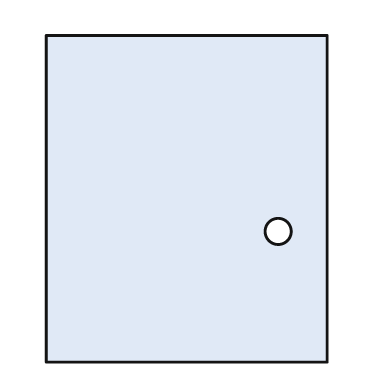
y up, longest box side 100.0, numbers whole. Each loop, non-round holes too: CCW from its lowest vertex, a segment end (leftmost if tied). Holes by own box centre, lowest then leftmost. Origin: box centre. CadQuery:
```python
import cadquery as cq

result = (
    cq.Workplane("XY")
    .moveTo(-43.0, -50.0)
    .lineTo(43.0, -50.0)
    .lineTo(43.0, 50.0)
    .lineTo(-43.0, 50.0)
    .close()
    .moveTo(28.0, -10.0)
    .circle(4.0)
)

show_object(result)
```